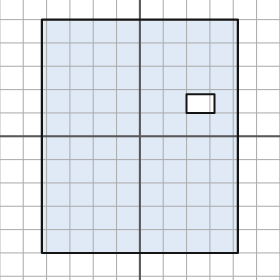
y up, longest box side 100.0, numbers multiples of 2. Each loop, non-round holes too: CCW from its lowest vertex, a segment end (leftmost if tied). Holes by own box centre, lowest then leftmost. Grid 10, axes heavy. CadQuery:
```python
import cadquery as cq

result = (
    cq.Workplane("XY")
    .moveTo(-42.0, -50.0)
    .lineTo(42.0, -50.0)
    .lineTo(42.0, 50.0)
    .lineTo(-42.0, 50.0)
    .close()
    .moveTo(20.0, 10.0)
    .lineTo(32.0, 10.0)
    .lineTo(32.0, 18.0)
    .lineTo(20.0, 18.0)
    .close()
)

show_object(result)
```